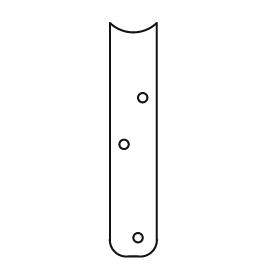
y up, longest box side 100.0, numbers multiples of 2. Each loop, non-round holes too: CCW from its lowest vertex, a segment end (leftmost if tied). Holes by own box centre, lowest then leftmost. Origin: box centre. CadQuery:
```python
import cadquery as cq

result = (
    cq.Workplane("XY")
    .moveTo(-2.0, -50.0)
    .lineTo(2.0, -50.0)
    .threePointArc((8.0, -48.0), (10.0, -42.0))
    .lineTo(10.0, 50.0)
    .threePointArc((0.0, 46.0), (-10.0, 50.0))
    .lineTo(-10.0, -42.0)
    .threePointArc((-8.0, -48.0), (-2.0, -50.0))
    .close()
    .moveTo(2.0, -42.0)
    .circle(2.0)
    .moveTo(-4.0, -2.0)
    .circle(2.0)
    .moveTo(4.0, 18.0)
    .circle(2.0)
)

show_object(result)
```